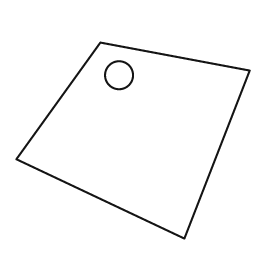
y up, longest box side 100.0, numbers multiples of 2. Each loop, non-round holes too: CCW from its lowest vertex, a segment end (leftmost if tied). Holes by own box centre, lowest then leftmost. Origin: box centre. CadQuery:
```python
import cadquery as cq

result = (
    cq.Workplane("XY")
    .moveTo(22.0, -42.0)
    .lineTo(50.0, 30.0)
    .lineTo(-14.0, 42.0)
    .lineTo(-50.0, -8.0)
    .close()
    .moveTo(-6.0, 28.0)
    .circle(6.0)
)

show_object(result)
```